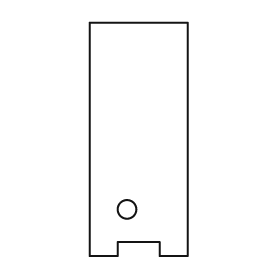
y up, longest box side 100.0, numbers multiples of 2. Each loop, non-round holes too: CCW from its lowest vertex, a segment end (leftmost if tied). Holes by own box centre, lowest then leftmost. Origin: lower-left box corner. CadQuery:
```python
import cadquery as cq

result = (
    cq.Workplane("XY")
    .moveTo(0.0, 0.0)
    .lineTo(12.0, 0.0)
    .lineTo(12.0, 6.0)
    .lineTo(30.0, 6.0)
    .lineTo(30.0, 0.0)
    .lineTo(42.0, 0.0)
    .lineTo(42.0, 100.0)
    .lineTo(0.0, 100.0)
    .close()
    .moveTo(16.0, 20.0)
    .circle(4.0)
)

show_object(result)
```